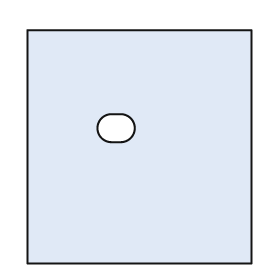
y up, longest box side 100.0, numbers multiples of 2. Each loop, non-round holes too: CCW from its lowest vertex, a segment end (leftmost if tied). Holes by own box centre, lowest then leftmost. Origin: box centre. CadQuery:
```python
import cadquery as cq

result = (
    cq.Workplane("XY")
    .moveTo(-48.0, -50.0)
    .lineTo(48.0, -50.0)
    .lineTo(48.0, 50.0)
    .lineTo(-48.0, 50.0)
    .close()
    .moveTo(-12.0, 2.0)
    .lineTo(-8.0, 2.0)
    .threePointArc((-2.0, 8.0), (-8.0, 14.0))
    .lineTo(-12.0, 14.0)
    .threePointArc((-18.0, 8.0), (-12.0, 2.0))
    .close()
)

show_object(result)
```